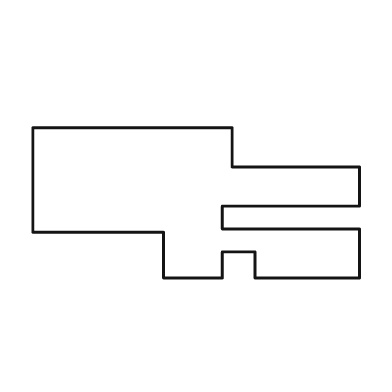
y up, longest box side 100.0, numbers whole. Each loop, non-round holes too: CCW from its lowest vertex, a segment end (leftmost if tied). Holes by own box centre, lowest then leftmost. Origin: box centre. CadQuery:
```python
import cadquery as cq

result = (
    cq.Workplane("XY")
    .moveTo(-10.0, -23.0)
    .lineTo(8.0, -23.0)
    .lineTo(8.0, -15.0)
    .lineTo(18.0, -15.0)
    .lineTo(18.0, -23.0)
    .lineTo(50.0, -23.0)
    .lineTo(50.0, -8.0)
    .lineTo(8.0, -8.0)
    .lineTo(8.0, -1.0)
    .lineTo(50.0, -1.0)
    .lineTo(50.0, 11.0)
    .lineTo(11.0, 11.0)
    .lineTo(11.0, 23.0)
    .lineTo(-50.0, 23.0)
    .lineTo(-50.0, -9.0)
    .lineTo(-10.0, -9.0)
    .close()
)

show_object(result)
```